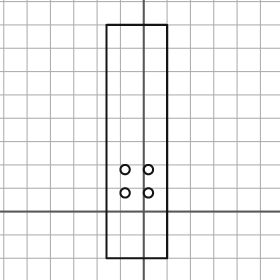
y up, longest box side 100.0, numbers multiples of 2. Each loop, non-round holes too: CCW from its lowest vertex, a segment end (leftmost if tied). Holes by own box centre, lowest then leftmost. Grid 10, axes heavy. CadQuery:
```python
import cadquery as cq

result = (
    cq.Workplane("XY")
    .moveTo(-16.0, -20.0)
    .lineTo(10.0, -20.0)
    .lineTo(10.0, 80.0)
    .lineTo(-16.0, 80.0)
    .close()
    .moveTo(-8.0, 8.0)
    .circle(2.0)
    .moveTo(2.0, 8.0)
    .circle(2.0)
    .moveTo(-8.0, 18.0)
    .circle(2.0)
    .moveTo(2.0, 18.0)
    .circle(2.0)
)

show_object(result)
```